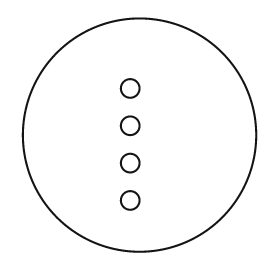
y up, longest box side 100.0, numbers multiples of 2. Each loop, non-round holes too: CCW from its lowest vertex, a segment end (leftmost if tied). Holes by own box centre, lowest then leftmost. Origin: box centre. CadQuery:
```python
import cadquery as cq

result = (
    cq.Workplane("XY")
    .moveTo(0.0, 0.0)
    .circle(50.0)
    .moveTo(-4.0, -28.0)
    .circle(4.0)
    .moveTo(-4.0, -12.0)
    .circle(4.0)
    .moveTo(-4.0, 4.0)
    .circle(4.0)
    .moveTo(-4.0, 20.0)
    .circle(4.0)
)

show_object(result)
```